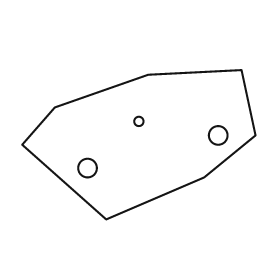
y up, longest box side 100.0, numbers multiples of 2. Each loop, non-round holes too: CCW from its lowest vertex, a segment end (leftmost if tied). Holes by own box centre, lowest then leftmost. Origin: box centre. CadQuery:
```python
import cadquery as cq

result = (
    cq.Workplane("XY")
    .moveTo(-14.0, -32.0)
    .lineTo(28.0, -14.0)
    .lineTo(50.0, 4.0)
    .lineTo(44.0, 32.0)
    .lineTo(4.0, 30.0)
    .lineTo(-36.0, 16.0)
    .lineTo(-50.0, 0.0)
    .close()
    .moveTo(-22.0, -10.0)
    .circle(4.0)
    .moveTo(34.0, 4.0)
    .circle(4.0)
    .moveTo(0.0, 10.0)
    .circle(2.0)
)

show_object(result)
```